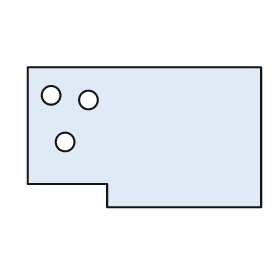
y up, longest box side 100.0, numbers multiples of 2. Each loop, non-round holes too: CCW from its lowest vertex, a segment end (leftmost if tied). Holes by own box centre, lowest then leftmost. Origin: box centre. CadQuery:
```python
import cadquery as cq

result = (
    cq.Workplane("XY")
    .moveTo(-16.0, -30.0)
    .lineTo(50.0, -30.0)
    .lineTo(50.0, 30.0)
    .lineTo(-50.0, 30.0)
    .lineTo(-50.0, -20.0)
    .lineTo(-16.0, -20.0)
    .close()
    .moveTo(-34.0, -2.0)
    .circle(4.0)
    .moveTo(-24.0, 16.0)
    .circle(4.0)
    .moveTo(-40.0, 18.0)
    .circle(4.0)
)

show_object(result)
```